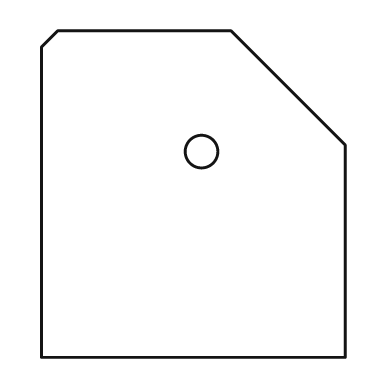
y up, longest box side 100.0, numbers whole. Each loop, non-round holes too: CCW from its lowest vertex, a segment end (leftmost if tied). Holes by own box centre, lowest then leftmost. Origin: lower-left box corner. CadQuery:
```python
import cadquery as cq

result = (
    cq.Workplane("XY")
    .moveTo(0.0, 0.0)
    .lineTo(93.0, 0.0)
    .lineTo(93.0, 65.0)
    .lineTo(58.0, 100.0)
    .lineTo(5.0, 100.0)
    .lineTo(0.0, 95.0)
    .close()
    .moveTo(49.0, 63.0)
    .circle(5.0)
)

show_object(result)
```